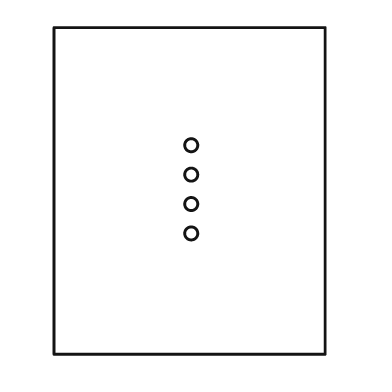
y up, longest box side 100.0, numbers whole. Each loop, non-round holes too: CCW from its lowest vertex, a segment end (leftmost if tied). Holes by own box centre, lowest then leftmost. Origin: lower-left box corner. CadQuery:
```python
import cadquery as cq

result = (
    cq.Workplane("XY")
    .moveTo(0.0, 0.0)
    .lineTo(83.0, 0.0)
    .lineTo(83.0, 100.0)
    .lineTo(0.0, 100.0)
    .close()
    .moveTo(42.0, 37.0)
    .circle(2.0)
    .moveTo(42.0, 46.0)
    .circle(2.0)
    .moveTo(42.0, 55.0)
    .circle(2.0)
    .moveTo(42.0, 64.0)
    .circle(2.0)
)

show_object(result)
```